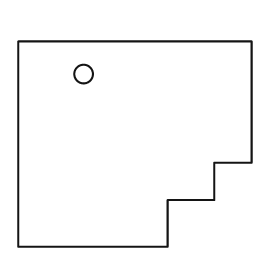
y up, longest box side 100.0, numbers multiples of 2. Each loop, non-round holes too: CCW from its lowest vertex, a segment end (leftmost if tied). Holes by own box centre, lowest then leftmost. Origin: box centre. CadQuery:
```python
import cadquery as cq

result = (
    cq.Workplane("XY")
    .moveTo(-50.0, -44.0)
    .lineTo(14.0, -44.0)
    .lineTo(14.0, -24.0)
    .lineTo(34.0, -24.0)
    .lineTo(34.0, -8.0)
    .lineTo(50.0, -8.0)
    .lineTo(50.0, 44.0)
    .lineTo(-50.0, 44.0)
    .close()
    .moveTo(-22.0, 30.0)
    .circle(4.0)
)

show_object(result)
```